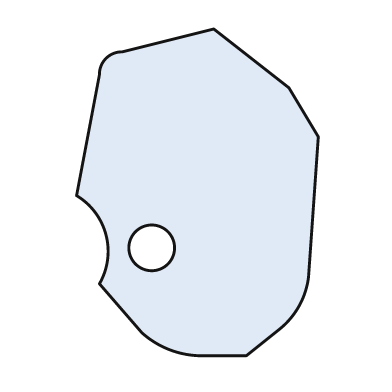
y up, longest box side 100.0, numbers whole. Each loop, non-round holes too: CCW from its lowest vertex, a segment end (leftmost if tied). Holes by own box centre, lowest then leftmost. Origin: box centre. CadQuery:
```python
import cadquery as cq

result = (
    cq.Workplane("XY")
    .moveTo(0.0, -50.0)
    .lineTo(15.0, -50.0)
    .lineTo(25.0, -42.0)
    .threePointArc((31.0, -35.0), (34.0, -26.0))
    .lineTo(37.0, 17.0)
    .lineTo(28.0, 32.0)
    .lineTo(5.0, 50.0)
    .lineTo(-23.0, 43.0)
    .threePointArc((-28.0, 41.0), (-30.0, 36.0))
    .lineTo(-37.0, -1.0)
    .threePointArc((-28.0, -13.0), (-30.0, -28.0))
    .lineTo(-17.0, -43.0)
    .threePointArc((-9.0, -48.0), (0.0, -50.0))
    .close()
    .moveTo(-14.0, -17.0)
    .circle(7.0)
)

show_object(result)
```